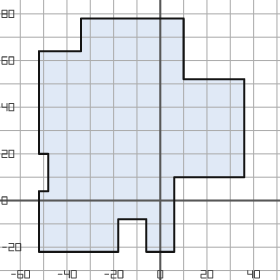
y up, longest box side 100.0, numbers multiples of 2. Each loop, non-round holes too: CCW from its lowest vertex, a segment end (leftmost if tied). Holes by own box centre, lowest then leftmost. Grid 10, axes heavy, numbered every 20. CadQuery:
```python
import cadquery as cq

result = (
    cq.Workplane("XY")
    .moveTo(-52.0, -22.0)
    .lineTo(-18.0, -22.0)
    .lineTo(-18.0, -8.0)
    .lineTo(-6.0, -8.0)
    .lineTo(-6.0, -22.0)
    .lineTo(6.0, -22.0)
    .lineTo(6.0, 10.0)
    .lineTo(36.0, 10.0)
    .lineTo(36.0, 52.0)
    .lineTo(10.0, 52.0)
    .lineTo(10.0, 78.0)
    .lineTo(-34.0, 78.0)
    .lineTo(-34.0, 64.0)
    .lineTo(-52.0, 64.0)
    .lineTo(-52.0, 20.0)
    .lineTo(-48.0, 20.0)
    .lineTo(-48.0, 4.0)
    .lineTo(-52.0, 4.0)
    .close()
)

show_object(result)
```